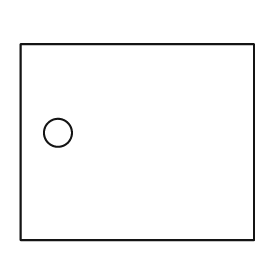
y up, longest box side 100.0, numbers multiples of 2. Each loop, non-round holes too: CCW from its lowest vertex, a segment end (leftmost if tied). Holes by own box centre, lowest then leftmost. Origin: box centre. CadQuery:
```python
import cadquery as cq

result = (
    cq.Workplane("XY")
    .moveTo(-50.0, -42.0)
    .lineTo(50.0, -42.0)
    .lineTo(50.0, 42.0)
    .lineTo(-50.0, 42.0)
    .close()
    .moveTo(-34.0, 4.0)
    .circle(6.0)
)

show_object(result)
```